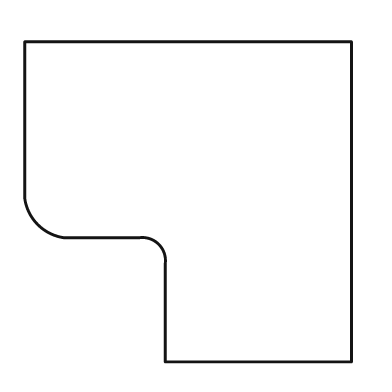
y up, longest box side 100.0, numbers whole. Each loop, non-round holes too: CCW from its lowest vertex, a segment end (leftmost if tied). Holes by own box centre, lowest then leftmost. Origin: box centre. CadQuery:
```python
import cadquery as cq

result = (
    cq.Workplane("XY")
    .moveTo(-7.0, -49.0)
    .lineTo(50.0, -49.0)
    .lineTo(50.0, 49.0)
    .lineTo(-50.0, 49.0)
    .lineTo(-50.0, 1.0)
    .threePointArc((-46.0, -7.0), (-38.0, -11.0))
    .lineTo(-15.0, -11.0)
    .threePointArc((-9.0, -13.0), (-7.0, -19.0))
    .close()
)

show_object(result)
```